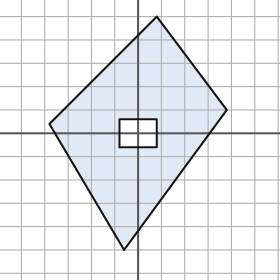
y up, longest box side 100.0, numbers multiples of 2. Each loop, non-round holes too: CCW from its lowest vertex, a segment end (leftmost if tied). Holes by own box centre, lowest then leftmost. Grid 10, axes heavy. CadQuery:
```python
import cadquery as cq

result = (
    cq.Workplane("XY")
    .moveTo(-6.0, -50.0)
    .lineTo(38.0, 10.0)
    .lineTo(8.0, 50.0)
    .lineTo(-38.0, 4.0)
    .close()
    .moveTo(-8.0, -6.0)
    .lineTo(8.0, -6.0)
    .lineTo(8.0, 6.0)
    .lineTo(-8.0, 6.0)
    .close()
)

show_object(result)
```